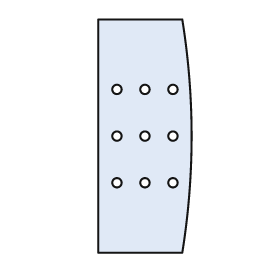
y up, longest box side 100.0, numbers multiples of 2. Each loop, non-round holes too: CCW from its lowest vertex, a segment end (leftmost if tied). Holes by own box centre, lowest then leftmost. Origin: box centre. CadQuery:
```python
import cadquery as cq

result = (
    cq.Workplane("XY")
    .moveTo(-20.0, -50.0)
    .lineTo(16.0, -50.0)
    .threePointArc((20.0, 0.0), (16.0, 50.0))
    .lineTo(-20.0, 50.0)
    .close()
    .moveTo(-12.0, -20.0)
    .circle(2.0)
    .moveTo(0.0, -20.0)
    .circle(2.0)
    .moveTo(12.0, -20.0)
    .circle(2.0)
    .moveTo(-12.0, 0.0)
    .circle(2.0)
    .moveTo(0.0, 0.0)
    .circle(2.0)
    .moveTo(12.0, 0.0)
    .circle(2.0)
    .moveTo(-12.0, 20.0)
    .circle(2.0)
    .moveTo(0.0, 20.0)
    .circle(2.0)
    .moveTo(12.0, 20.0)
    .circle(2.0)
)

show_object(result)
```